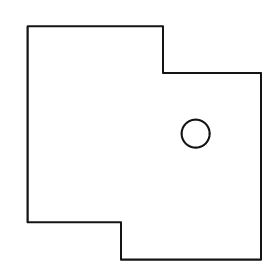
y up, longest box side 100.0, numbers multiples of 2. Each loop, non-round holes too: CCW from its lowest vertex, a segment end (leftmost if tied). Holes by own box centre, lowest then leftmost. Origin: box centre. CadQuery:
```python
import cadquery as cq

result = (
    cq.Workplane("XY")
    .moveTo(-10.0, -50.0)
    .lineTo(50.0, -50.0)
    .lineTo(50.0, 30.0)
    .lineTo(8.0, 30.0)
    .lineTo(8.0, 50.0)
    .lineTo(-50.0, 50.0)
    .lineTo(-50.0, -34.0)
    .lineTo(-10.0, -34.0)
    .close()
    .moveTo(22.0, 4.0)
    .circle(6.0)
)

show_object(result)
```